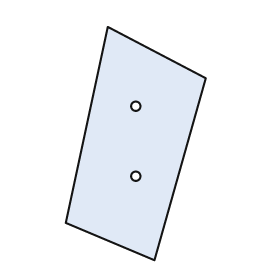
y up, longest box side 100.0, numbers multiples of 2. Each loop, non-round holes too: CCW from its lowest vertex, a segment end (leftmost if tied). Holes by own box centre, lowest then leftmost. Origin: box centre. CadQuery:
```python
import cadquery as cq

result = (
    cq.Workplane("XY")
    .moveTo(8.0, -50.0)
    .lineTo(30.0, 28.0)
    .lineTo(-12.0, 50.0)
    .lineTo(-30.0, -34.0)
    .close()
    .moveTo(0.0, -14.0)
    .circle(2.0)
    .moveTo(0.0, 16.0)
    .circle(2.0)
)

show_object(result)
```